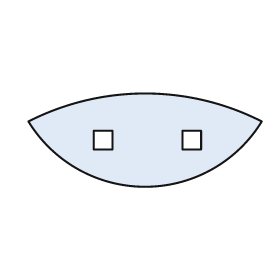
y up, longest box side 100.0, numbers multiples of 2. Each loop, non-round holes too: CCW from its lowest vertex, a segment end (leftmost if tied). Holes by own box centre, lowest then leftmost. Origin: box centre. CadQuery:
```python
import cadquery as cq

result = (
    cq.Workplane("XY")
    .moveTo(-50.0, 8.0)
    .threePointArc((0.0, -20.0), (50.0, 8.0))
    .threePointArc((0.0, 20.0), (-50.0, 8.0))
    .close()
    .moveTo(-22.0, -4.0)
    .lineTo(-14.0, -4.0)
    .lineTo(-14.0, 4.0)
    .lineTo(-22.0, 4.0)
    .close()
    .moveTo(16.0, -4.0)
    .lineTo(24.0, -4.0)
    .lineTo(24.0, 4.0)
    .lineTo(16.0, 4.0)
    .close()
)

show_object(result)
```